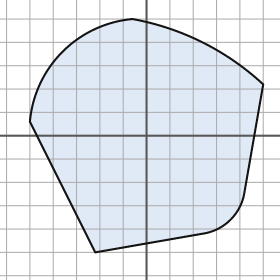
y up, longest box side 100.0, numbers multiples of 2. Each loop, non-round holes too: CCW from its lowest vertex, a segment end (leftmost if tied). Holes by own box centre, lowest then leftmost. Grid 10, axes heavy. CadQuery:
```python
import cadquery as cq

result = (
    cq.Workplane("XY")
    .moveTo(-22.0, -50.0)
    .lineTo(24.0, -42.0)
    .threePointArc((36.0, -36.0), (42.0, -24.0))
    .lineTo(50.0, 22.0)
    .threePointArc((24.0, 40.0), (-6.0, 50.0))
    .threePointArc((-36.0, 36.0), (-50.0, 6.0))
    .close()
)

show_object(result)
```